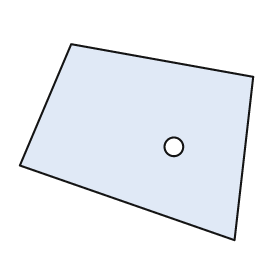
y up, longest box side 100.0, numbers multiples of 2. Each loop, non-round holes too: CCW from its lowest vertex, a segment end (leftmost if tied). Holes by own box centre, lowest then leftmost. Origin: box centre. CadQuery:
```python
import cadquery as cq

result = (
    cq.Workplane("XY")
    .moveTo(42.0, -42.0)
    .lineTo(50.0, 28.0)
    .lineTo(-28.0, 42.0)
    .lineTo(-50.0, -10.0)
    .close()
    .moveTo(16.0, -2.0)
    .circle(4.0)
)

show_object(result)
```